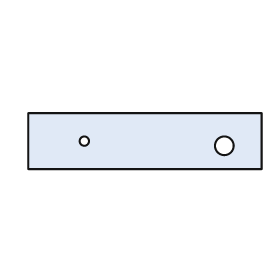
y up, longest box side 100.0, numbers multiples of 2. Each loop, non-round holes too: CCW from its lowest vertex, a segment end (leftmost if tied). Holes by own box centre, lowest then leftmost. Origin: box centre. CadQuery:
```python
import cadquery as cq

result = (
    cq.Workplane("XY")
    .moveTo(-50.0, -12.0)
    .lineTo(50.0, -12.0)
    .lineTo(50.0, 12.0)
    .lineTo(-50.0, 12.0)
    .close()
    .moveTo(34.0, -2.0)
    .circle(4.0)
    .moveTo(-26.0, 0.0)
    .circle(2.0)
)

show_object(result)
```